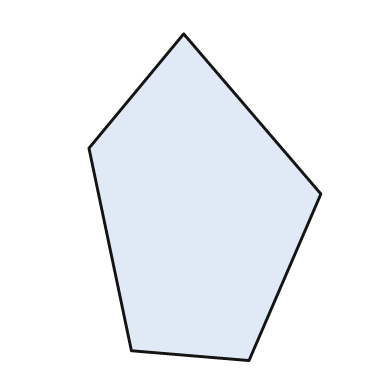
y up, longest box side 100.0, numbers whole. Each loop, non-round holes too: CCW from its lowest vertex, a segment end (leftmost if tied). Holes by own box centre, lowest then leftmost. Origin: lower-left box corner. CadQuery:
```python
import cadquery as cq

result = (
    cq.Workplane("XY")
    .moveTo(49.0, 0.0)
    .lineTo(71.0, 51.0)
    .lineTo(29.0, 100.0)
    .lineTo(0.0, 65.0)
    .lineTo(13.0, 3.0)
    .close()
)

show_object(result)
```